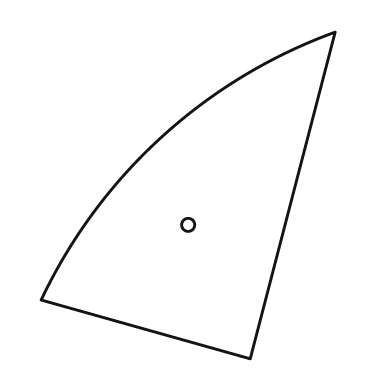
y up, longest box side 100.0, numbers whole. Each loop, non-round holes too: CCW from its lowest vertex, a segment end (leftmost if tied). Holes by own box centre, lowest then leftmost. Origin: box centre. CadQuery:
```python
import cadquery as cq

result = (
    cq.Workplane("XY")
    .moveTo(19.0, -50.0)
    .lineTo(45.0, 50.0)
    .threePointArc((-8.0, 18.0), (-45.0, -32.0))
    .close()
    .moveTo(0.0, -9.0)
    .circle(2.0)
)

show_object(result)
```